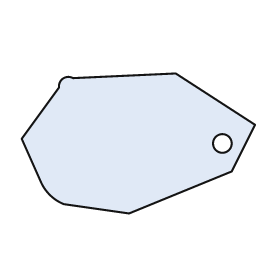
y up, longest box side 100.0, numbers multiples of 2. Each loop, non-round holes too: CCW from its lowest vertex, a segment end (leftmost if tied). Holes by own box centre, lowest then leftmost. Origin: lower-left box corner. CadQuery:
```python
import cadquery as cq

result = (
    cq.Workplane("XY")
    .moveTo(46.0, 0.0)
    .lineTo(90.0, 18.0)
    .lineTo(100.0, 38.0)
    .lineTo(66.0, 60.0)
    .lineTo(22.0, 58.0)
    .threePointArc((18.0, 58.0), (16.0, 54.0))
    .lineTo(0.0, 32.0)
    .lineTo(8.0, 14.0)
    .threePointArc((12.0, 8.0), (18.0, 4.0))
    .close()
    .moveTo(86.0, 30.0)
    .circle(4.0)
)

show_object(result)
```